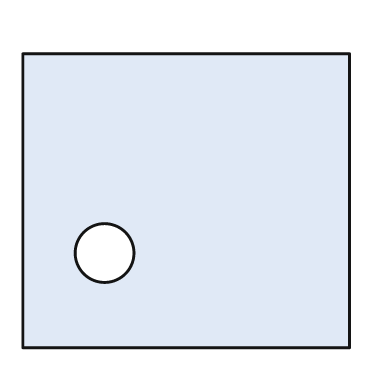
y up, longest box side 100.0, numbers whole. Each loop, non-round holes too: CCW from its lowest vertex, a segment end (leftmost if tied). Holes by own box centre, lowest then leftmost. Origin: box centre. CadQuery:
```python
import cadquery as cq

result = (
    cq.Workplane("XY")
    .moveTo(-50.0, -45.0)
    .lineTo(50.0, -45.0)
    .lineTo(50.0, 45.0)
    .lineTo(-50.0, 45.0)
    .close()
    .moveTo(-25.0, -16.0)
    .circle(9.0)
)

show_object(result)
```